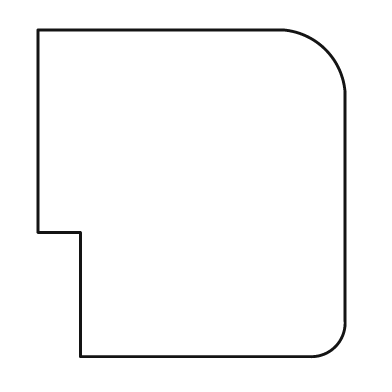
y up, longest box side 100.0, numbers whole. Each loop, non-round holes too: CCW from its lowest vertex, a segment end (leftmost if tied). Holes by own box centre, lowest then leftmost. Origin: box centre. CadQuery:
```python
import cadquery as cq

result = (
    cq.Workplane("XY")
    .moveTo(-34.0, -50.0)
    .lineTo(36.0, -50.0)
    .threePointArc((44.0, -47.0), (47.0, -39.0))
    .lineTo(47.0, 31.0)
    .threePointArc((41.0, 44.0), (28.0, 50.0))
    .lineTo(-47.0, 50.0)
    .lineTo(-47.0, -12.0)
    .lineTo(-34.0, -12.0)
    .close()
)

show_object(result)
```